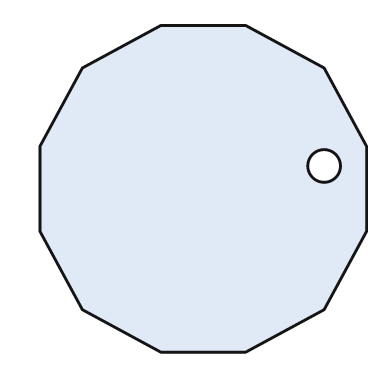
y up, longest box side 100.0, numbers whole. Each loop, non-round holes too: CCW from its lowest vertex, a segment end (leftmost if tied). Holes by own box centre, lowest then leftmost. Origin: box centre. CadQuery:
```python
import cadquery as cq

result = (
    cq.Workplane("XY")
    .moveTo(-13.0, -50.0)
    .lineTo(13.0, -50.0)
    .lineTo(37.0, -37.0)
    .lineTo(50.0, -13.0)
    .lineTo(50.0, 13.0)
    .lineTo(37.0, 37.0)
    .lineTo(13.0, 50.0)
    .lineTo(-13.0, 50.0)
    .lineTo(-37.0, 37.0)
    .lineTo(-50.0, 13.0)
    .lineTo(-50.0, -13.0)
    .lineTo(-37.0, -37.0)
    .close()
    .moveTo(37.0, 7.0)
    .circle(5.0)
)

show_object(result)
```